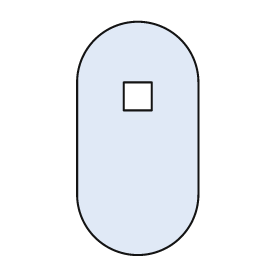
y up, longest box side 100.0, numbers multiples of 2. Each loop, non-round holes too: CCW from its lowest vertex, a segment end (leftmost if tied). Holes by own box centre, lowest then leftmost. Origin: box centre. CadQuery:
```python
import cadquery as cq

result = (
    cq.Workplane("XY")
    .moveTo(-26.0, -24.0)
    .threePointArc((0.0, -50.0), (26.0, -24.0))
    .lineTo(26.0, 24.0)
    .threePointArc((0.0, 50.0), (-26.0, 24.0))
    .close()
    .moveTo(-6.0, 12.0)
    .lineTo(6.0, 12.0)
    .lineTo(6.0, 24.0)
    .lineTo(-6.0, 24.0)
    .close()
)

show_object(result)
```